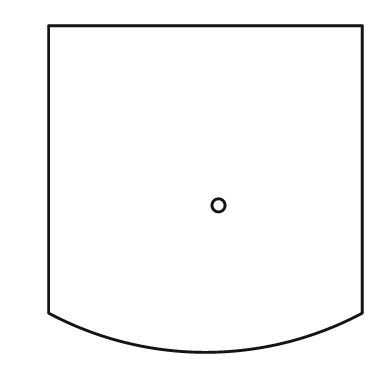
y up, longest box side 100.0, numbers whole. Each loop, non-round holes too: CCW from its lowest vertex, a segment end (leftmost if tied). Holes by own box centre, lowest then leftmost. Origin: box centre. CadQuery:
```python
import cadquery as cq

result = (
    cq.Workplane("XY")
    .moveTo(-48.0, -38.0)
    .threePointArc((0.0, -50.0), (48.0, -38.0))
    .lineTo(48.0, 50.0)
    .lineTo(-48.0, 50.0)
    .close()
    .moveTo(4.0, -5.0)
    .circle(2.0)
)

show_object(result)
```